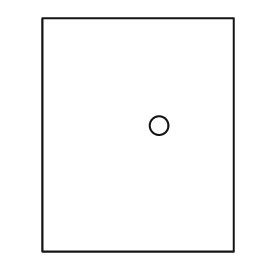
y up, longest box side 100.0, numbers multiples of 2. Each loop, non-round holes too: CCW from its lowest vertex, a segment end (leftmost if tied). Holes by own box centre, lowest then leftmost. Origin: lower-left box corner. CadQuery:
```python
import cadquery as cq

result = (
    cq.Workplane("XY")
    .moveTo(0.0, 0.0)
    .lineTo(82.0, 0.0)
    .lineTo(82.0, 100.0)
    .lineTo(0.0, 100.0)
    .close()
    .moveTo(50.0, 54.0)
    .circle(4.0)
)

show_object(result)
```